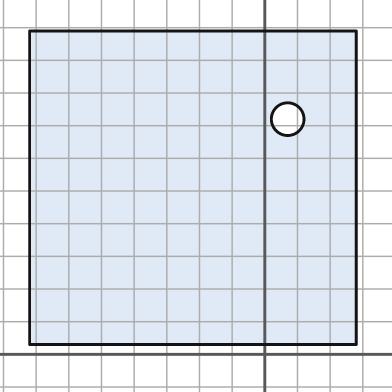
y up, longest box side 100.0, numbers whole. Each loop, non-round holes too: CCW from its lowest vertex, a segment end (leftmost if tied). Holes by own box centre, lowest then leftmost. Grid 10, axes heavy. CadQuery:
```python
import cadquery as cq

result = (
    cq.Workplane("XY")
    .moveTo(-72.0, 3.0)
    .lineTo(28.0, 3.0)
    .lineTo(28.0, 99.0)
    .lineTo(-72.0, 99.0)
    .close()
    .moveTo(7.0, 72.0)
    .circle(5.0)
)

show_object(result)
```